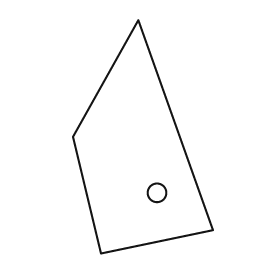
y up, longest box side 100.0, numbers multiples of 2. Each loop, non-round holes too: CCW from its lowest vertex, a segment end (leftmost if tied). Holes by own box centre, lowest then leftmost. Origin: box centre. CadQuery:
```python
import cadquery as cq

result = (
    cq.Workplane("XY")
    .moveTo(-18.0, -50.0)
    .lineTo(30.0, -40.0)
    .lineTo(-2.0, 50.0)
    .lineTo(-30.0, 0.0)
    .close()
    .moveTo(6.0, -24.0)
    .circle(4.0)
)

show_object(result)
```